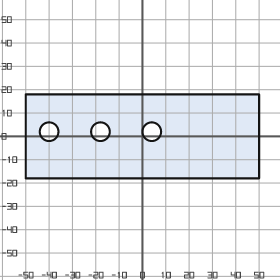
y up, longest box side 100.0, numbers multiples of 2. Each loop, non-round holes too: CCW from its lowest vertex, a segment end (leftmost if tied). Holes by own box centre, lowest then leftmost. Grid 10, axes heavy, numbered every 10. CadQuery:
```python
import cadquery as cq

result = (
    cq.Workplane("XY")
    .moveTo(-50.0, -18.0)
    .lineTo(50.0, -18.0)
    .lineTo(50.0, 18.0)
    .lineTo(-50.0, 18.0)
    .close()
    .moveTo(-40.0, 2.0)
    .circle(4.0)
    .moveTo(-18.0, 2.0)
    .circle(4.0)
    .moveTo(4.0, 2.0)
    .circle(4.0)
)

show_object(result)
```